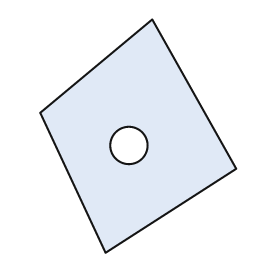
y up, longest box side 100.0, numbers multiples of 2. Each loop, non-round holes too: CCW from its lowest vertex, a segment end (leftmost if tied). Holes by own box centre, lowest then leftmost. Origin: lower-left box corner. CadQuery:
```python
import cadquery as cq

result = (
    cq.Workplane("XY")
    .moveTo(28.0, 0.0)
    .lineTo(84.0, 36.0)
    .lineTo(48.0, 100.0)
    .lineTo(0.0, 60.0)
    .close()
    .moveTo(38.0, 46.0)
    .circle(8.0)
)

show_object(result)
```